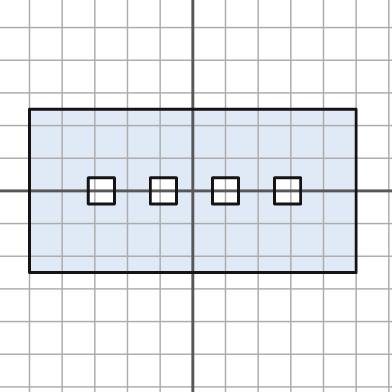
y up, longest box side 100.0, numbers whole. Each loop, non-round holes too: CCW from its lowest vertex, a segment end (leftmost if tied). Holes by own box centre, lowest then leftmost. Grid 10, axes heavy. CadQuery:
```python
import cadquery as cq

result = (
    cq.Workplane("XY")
    .moveTo(-50.0, -25.0)
    .lineTo(50.0, -25.0)
    .lineTo(50.0, 25.0)
    .lineTo(-50.0, 25.0)
    .close()
    .moveTo(-32.0, -4.0)
    .lineTo(-24.0, -4.0)
    .lineTo(-24.0, 4.0)
    .lineTo(-32.0, 4.0)
    .close()
    .moveTo(-13.0, -4.0)
    .lineTo(-5.0, -4.0)
    .lineTo(-5.0, 4.0)
    .lineTo(-13.0, 4.0)
    .close()
    .moveTo(6.0, -4.0)
    .lineTo(14.0, -4.0)
    .lineTo(14.0, 4.0)
    .lineTo(6.0, 4.0)
    .close()
    .moveTo(25.0, -4.0)
    .lineTo(33.0, -4.0)
    .lineTo(33.0, 4.0)
    .lineTo(25.0, 4.0)
    .close()
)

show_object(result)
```